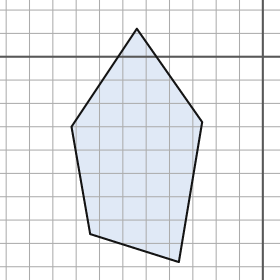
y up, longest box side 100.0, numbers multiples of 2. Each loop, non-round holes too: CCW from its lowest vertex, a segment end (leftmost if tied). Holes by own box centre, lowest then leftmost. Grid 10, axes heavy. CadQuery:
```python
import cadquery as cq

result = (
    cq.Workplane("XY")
    .moveTo(-36.0, -88.0)
    .lineTo(-26.0, -28.0)
    .lineTo(-54.0, 12.0)
    .lineTo(-82.0, -30.0)
    .lineTo(-74.0, -76.0)
    .close()
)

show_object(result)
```